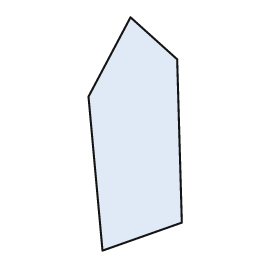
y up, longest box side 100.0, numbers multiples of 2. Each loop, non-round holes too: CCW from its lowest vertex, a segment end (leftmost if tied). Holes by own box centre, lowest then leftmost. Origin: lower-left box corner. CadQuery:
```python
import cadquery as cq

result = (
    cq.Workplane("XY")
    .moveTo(6.0, 0.0)
    .lineTo(40.0, 12.0)
    .lineTo(38.0, 82.0)
    .lineTo(18.0, 100.0)
    .lineTo(0.0, 66.0)
    .close()
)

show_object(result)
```